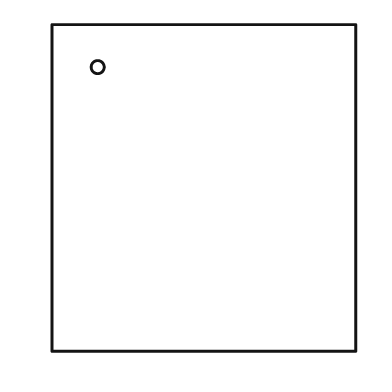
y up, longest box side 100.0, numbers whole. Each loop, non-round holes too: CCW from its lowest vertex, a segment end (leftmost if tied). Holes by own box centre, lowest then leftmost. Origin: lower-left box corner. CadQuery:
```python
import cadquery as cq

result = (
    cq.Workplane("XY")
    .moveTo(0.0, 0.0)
    .lineTo(93.0, 0.0)
    .lineTo(93.0, 100.0)
    .lineTo(0.0, 100.0)
    .close()
    .moveTo(14.0, 87.0)
    .circle(2.0)
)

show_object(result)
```